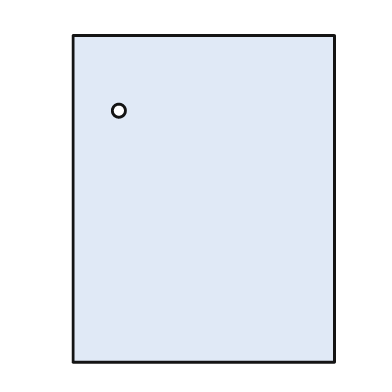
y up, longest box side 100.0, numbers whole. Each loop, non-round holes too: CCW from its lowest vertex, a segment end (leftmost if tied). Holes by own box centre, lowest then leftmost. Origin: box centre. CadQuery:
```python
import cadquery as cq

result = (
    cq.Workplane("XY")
    .moveTo(-40.0, -50.0)
    .lineTo(40.0, -50.0)
    .lineTo(40.0, 50.0)
    .lineTo(-40.0, 50.0)
    .close()
    .moveTo(-26.0, 27.0)
    .circle(2.0)
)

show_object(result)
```